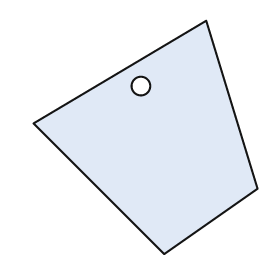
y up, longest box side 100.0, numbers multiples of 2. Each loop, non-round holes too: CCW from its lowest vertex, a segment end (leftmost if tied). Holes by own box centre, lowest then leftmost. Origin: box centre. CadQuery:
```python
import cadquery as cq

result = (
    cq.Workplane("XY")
    .moveTo(8.0, -50.0)
    .lineTo(48.0, -22.0)
    .lineTo(26.0, 50.0)
    .lineTo(-48.0, 6.0)
    .close()
    .moveTo(-2.0, 22.0)
    .circle(4.0)
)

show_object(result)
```